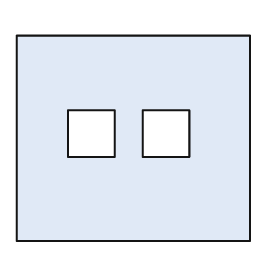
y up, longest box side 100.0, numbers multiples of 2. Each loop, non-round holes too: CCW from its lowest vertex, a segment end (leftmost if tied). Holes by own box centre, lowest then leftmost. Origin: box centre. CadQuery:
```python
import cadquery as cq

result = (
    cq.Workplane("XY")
    .moveTo(-50.0, -44.0)
    .lineTo(50.0, -44.0)
    .lineTo(50.0, 44.0)
    .lineTo(-50.0, 44.0)
    .close()
    .moveTo(-28.0, -8.0)
    .lineTo(-8.0, -8.0)
    .lineTo(-8.0, 12.0)
    .lineTo(-28.0, 12.0)
    .close()
    .moveTo(4.0, -8.0)
    .lineTo(24.0, -8.0)
    .lineTo(24.0, 12.0)
    .lineTo(4.0, 12.0)
    .close()
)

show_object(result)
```